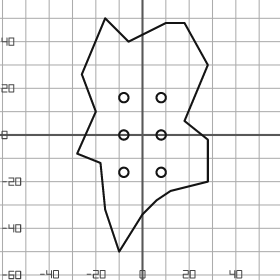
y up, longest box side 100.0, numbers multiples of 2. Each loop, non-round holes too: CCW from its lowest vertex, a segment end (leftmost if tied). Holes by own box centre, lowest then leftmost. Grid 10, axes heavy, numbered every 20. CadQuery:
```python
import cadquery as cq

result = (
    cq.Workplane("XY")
    .moveTo(-10.0, -50.0)
    .lineTo(0.0, -34.0)
    .lineTo(6.0, -28.0)
    .lineTo(12.0, -24.0)
    .lineTo(28.0, -20.0)
    .lineTo(28.0, -2.0)
    .lineTo(18.0, 6.0)
    .lineTo(28.0, 30.0)
    .lineTo(18.0, 48.0)
    .lineTo(10.0, 48.0)
    .lineTo(-6.0, 40.0)
    .lineTo(-16.0, 50.0)
    .lineTo(-26.0, 26.0)
    .lineTo(-20.0, 10.0)
    .lineTo(-28.0, -8.0)
    .lineTo(-18.0, -12.0)
    .lineTo(-16.0, -32.0)
    .close()
    .moveTo(-8.0, -16.0)
    .circle(2.0)
    .moveTo(8.0, -16.0)
    .circle(2.0)
    .moveTo(-8.0, 0.0)
    .circle(2.0)
    .moveTo(8.0, 0.0)
    .circle(2.0)
    .moveTo(-8.0, 16.0)
    .circle(2.0)
    .moveTo(8.0, 16.0)
    .circle(2.0)
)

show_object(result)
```